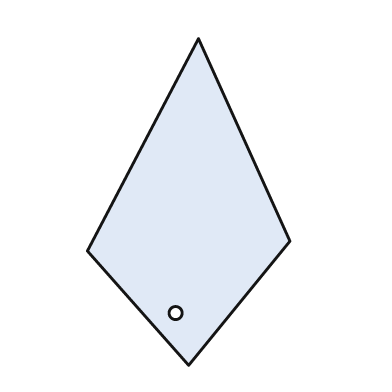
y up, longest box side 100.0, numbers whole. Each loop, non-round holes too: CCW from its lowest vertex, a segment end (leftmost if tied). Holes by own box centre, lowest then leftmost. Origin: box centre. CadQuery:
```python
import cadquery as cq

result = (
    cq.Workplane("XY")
    .moveTo(0.0, -50.0)
    .lineTo(31.0, -12.0)
    .lineTo(3.0, 50.0)
    .lineTo(-31.0, -15.0)
    .close()
    .moveTo(-4.0, -34.0)
    .circle(2.0)
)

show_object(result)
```